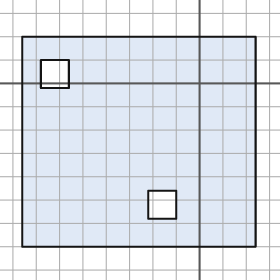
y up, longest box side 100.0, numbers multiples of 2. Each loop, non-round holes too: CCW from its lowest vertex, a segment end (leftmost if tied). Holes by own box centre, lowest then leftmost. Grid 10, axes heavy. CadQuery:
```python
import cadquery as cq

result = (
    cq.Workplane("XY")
    .moveTo(-76.0, -70.0)
    .lineTo(24.0, -70.0)
    .lineTo(24.0, 20.0)
    .lineTo(-76.0, 20.0)
    .close()
    .moveTo(-22.0, -58.0)
    .lineTo(-10.0, -58.0)
    .lineTo(-10.0, -46.0)
    .lineTo(-22.0, -46.0)
    .close()
    .moveTo(-68.0, -2.0)
    .lineTo(-56.0, -2.0)
    .lineTo(-56.0, 10.0)
    .lineTo(-68.0, 10.0)
    .close()
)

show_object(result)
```